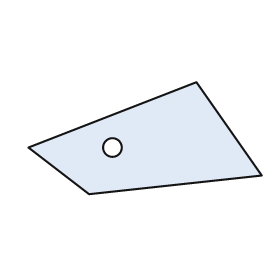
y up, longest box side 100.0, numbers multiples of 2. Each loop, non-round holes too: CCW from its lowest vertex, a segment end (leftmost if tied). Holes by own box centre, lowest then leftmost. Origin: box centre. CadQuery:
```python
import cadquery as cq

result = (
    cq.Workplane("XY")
    .moveTo(-24.0, -24.0)
    .lineTo(50.0, -16.0)
    .lineTo(22.0, 24.0)
    .lineTo(-50.0, -4.0)
    .close()
    .moveTo(-14.0, -4.0)
    .circle(4.0)
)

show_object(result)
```